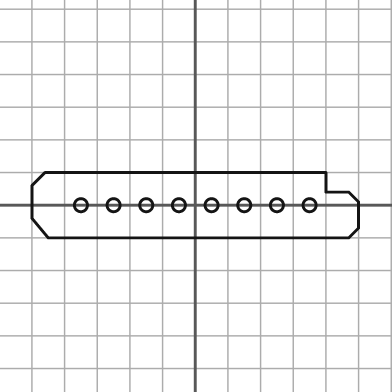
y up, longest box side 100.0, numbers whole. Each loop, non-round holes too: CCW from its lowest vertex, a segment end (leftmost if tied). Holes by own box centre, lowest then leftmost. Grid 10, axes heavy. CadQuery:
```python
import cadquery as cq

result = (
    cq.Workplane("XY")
    .moveTo(-45.0, -10.0)
    .lineTo(47.0, -10.0)
    .lineTo(50.0, -7.0)
    .lineTo(50.0, 1.0)
    .lineTo(47.0, 4.0)
    .lineTo(40.0, 4.0)
    .lineTo(40.0, 10.0)
    .lineTo(-46.0, 10.0)
    .lineTo(-50.0, 6.0)
    .lineTo(-50.0, -4.0)
    .close()
    .moveTo(-35.0, 0.0)
    .circle(2.0)
    .moveTo(-25.0, 0.0)
    .circle(2.0)
    .moveTo(-15.0, 0.0)
    .circle(2.0)
    .moveTo(-5.0, 0.0)
    .circle(2.0)
    .moveTo(5.0, 0.0)
    .circle(2.0)
    .moveTo(15.0, 0.0)
    .circle(2.0)
    .moveTo(25.0, 0.0)
    .circle(2.0)
    .moveTo(35.0, 0.0)
    .circle(2.0)
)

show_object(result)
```